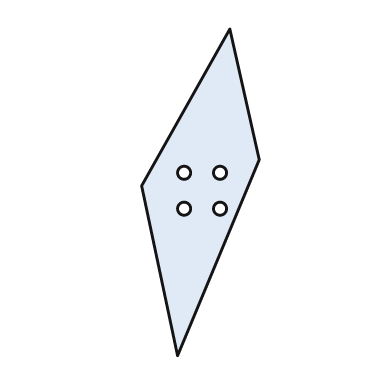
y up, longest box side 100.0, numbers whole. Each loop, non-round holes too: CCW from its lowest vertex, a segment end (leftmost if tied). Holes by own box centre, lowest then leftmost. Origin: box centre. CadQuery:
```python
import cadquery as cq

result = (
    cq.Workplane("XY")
    .moveTo(-7.0, -50.0)
    .lineTo(18.0, 10.0)
    .lineTo(9.0, 50.0)
    .lineTo(-18.0, 2.0)
    .close()
    .moveTo(-5.0, -5.0)
    .circle(2.0)
    .moveTo(6.0, -5.0)
    .circle(2.0)
    .moveTo(-5.0, 6.0)
    .circle(2.0)
    .moveTo(6.0, 6.0)
    .circle(2.0)
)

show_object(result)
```